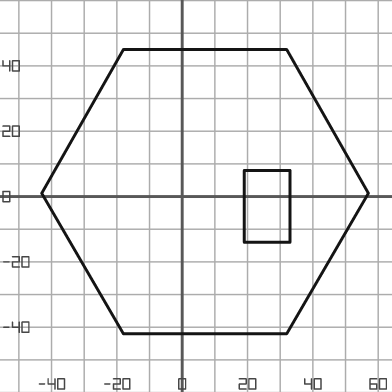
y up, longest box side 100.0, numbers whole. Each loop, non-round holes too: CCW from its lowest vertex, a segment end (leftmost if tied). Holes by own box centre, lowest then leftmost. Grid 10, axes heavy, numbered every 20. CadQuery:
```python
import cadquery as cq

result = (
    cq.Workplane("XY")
    .moveTo(-18.0, -42.0)
    .lineTo(32.0, -42.0)
    .lineTo(57.0, 1.0)
    .lineTo(32.0, 45.0)
    .lineTo(-18.0, 45.0)
    .lineTo(-43.0, 1.0)
    .close()
    .moveTo(19.0, -14.0)
    .lineTo(33.0, -14.0)
    .lineTo(33.0, 8.0)
    .lineTo(19.0, 8.0)
    .close()
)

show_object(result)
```